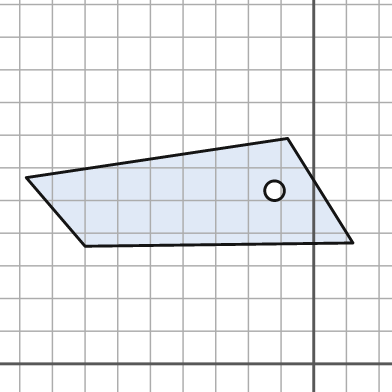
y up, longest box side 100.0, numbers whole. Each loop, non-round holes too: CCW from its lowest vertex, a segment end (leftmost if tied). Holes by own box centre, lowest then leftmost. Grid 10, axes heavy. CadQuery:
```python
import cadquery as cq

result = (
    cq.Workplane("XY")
    .moveTo(-70.0, 36.0)
    .lineTo(12.0, 37.0)
    .lineTo(-8.0, 69.0)
    .lineTo(-88.0, 57.0)
    .close()
    .moveTo(-12.0, 53.0)
    .circle(3.0)
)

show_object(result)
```